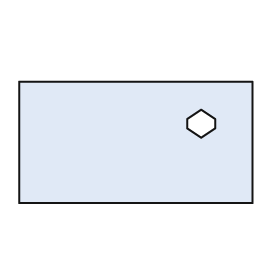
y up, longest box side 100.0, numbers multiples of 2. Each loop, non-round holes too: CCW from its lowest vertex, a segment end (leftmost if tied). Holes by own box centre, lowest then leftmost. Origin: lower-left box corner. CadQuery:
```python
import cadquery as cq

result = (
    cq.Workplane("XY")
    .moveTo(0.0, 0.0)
    .lineTo(100.0, 0.0)
    .lineTo(100.0, 52.0)
    .lineTo(0.0, 52.0)
    .close()
    .moveTo(78.0, 28.0)
    .lineTo(84.0, 32.0)
    .lineTo(84.0, 36.0)
    .lineTo(78.0, 40.0)
    .lineTo(72.0, 36.0)
    .lineTo(72.0, 32.0)
    .close()
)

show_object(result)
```